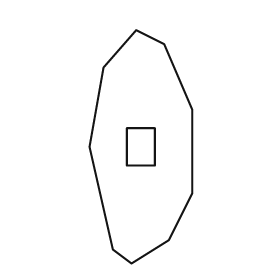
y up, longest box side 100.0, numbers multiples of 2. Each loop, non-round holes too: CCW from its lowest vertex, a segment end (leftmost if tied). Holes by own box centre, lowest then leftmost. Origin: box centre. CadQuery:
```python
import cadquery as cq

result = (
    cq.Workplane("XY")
    .moveTo(-4.0, -50.0)
    .lineTo(12.0, -40.0)
    .lineTo(22.0, -20.0)
    .lineTo(22.0, 16.0)
    .lineTo(10.0, 44.0)
    .lineTo(-2.0, 50.0)
    .lineTo(-16.0, 34.0)
    .lineTo(-22.0, 0.0)
    .lineTo(-12.0, -44.0)
    .close()
    .moveTo(-6.0, -8.0)
    .lineTo(6.0, -8.0)
    .lineTo(6.0, 8.0)
    .lineTo(-6.0, 8.0)
    .close()
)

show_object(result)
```